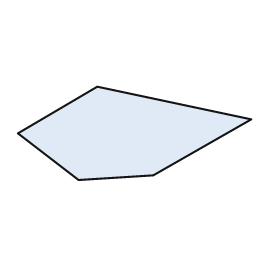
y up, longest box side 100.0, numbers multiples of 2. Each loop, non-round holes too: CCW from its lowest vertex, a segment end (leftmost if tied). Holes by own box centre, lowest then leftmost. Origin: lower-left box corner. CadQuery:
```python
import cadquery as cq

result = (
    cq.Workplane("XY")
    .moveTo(26.0, 0.0)
    .lineTo(58.0, 2.0)
    .lineTo(100.0, 26.0)
    .lineTo(34.0, 40.0)
    .lineTo(0.0, 20.0)
    .close()
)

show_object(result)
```